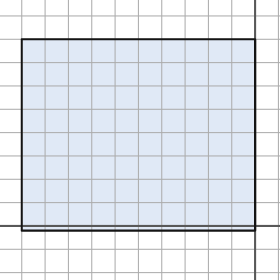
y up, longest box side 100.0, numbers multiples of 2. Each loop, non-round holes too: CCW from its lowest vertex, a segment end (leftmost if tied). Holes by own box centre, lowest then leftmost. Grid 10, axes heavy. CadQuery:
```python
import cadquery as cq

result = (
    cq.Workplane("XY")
    .moveTo(-100.0, -2.0)
    .lineTo(0.0, -2.0)
    .lineTo(0.0, 80.0)
    .lineTo(-100.0, 80.0)
    .close()
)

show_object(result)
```